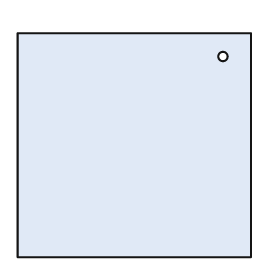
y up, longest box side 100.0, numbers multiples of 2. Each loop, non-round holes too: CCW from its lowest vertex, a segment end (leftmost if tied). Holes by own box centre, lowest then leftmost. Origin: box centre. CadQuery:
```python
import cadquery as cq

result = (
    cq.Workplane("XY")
    .moveTo(-50.0, -48.0)
    .lineTo(50.0, -48.0)
    .lineTo(50.0, 48.0)
    .lineTo(-50.0, 48.0)
    .close()
    .moveTo(38.0, 38.0)
    .circle(2.0)
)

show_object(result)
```